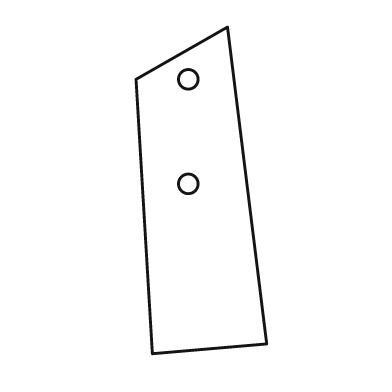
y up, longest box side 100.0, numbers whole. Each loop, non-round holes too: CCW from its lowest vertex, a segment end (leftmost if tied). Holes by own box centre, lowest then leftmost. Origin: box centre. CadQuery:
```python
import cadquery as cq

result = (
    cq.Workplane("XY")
    .moveTo(-15.0, -50.0)
    .lineTo(20.0, -47.0)
    .lineTo(8.0, 50.0)
    .lineTo(-20.0, 34.0)
    .close()
    .moveTo(-4.0, 2.0)
    .circle(3.0)
    .moveTo(-4.0, 34.0)
    .circle(3.0)
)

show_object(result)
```